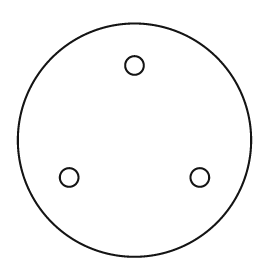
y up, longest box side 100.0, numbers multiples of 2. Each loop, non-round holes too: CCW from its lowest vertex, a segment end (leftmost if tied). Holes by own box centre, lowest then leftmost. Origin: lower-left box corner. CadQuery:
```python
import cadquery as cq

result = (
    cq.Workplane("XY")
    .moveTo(50.0, 50.0)
    .circle(50.0)
    .moveTo(22.0, 34.0)
    .circle(4.0)
    .moveTo(78.0, 34.0)
    .circle(4.0)
    .moveTo(50.0, 82.0)
    .circle(4.0)
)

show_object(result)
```